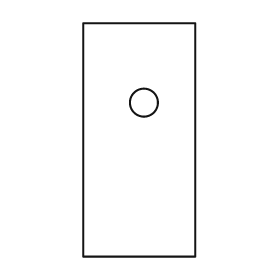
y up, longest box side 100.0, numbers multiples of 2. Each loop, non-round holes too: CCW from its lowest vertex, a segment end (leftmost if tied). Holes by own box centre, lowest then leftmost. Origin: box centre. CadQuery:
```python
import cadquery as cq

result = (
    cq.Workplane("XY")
    .moveTo(-24.0, -50.0)
    .lineTo(24.0, -50.0)
    .lineTo(24.0, 50.0)
    .lineTo(-24.0, 50.0)
    .close()
    .moveTo(2.0, 16.0)
    .circle(6.0)
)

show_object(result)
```